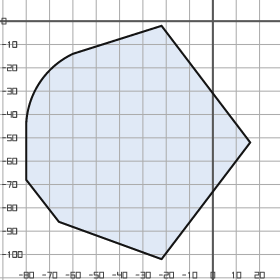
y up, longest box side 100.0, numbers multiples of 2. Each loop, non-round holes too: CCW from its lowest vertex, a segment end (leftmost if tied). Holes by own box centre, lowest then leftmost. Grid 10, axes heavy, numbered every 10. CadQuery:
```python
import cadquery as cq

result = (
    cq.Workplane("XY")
    .moveTo(-22.0, -102.0)
    .lineTo(16.0, -52.0)
    .lineTo(-22.0, -2.0)
    .lineTo(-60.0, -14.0)
    .threePointArc((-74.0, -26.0), (-80.0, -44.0))
    .lineTo(-80.0, -68.0)
    .lineTo(-66.0, -86.0)
    .close()
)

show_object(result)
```